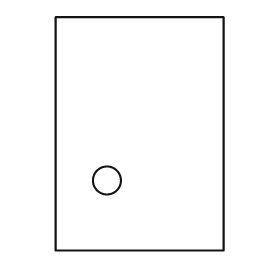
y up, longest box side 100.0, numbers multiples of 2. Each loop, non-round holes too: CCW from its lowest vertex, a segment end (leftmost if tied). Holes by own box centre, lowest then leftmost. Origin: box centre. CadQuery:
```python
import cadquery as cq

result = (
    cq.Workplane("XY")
    .moveTo(-36.0, -50.0)
    .lineTo(36.0, -50.0)
    .lineTo(36.0, 50.0)
    .lineTo(-36.0, 50.0)
    .close()
    .moveTo(-14.0, -20.0)
    .circle(6.0)
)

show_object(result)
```